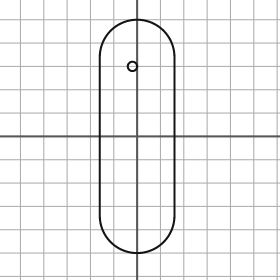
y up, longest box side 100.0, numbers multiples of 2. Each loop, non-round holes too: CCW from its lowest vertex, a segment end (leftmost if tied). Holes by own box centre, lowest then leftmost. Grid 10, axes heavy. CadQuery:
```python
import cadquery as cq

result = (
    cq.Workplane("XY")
    .moveTo(-16.0, -34.0)
    .threePointArc((0.0, -50.0), (16.0, -34.0))
    .lineTo(16.0, 34.0)
    .threePointArc((0.0, 50.0), (-16.0, 34.0))
    .close()
    .moveTo(-2.0, 30.0)
    .circle(2.0)
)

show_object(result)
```